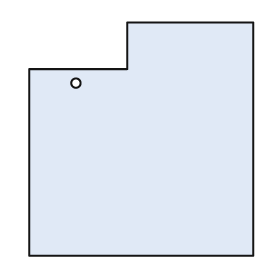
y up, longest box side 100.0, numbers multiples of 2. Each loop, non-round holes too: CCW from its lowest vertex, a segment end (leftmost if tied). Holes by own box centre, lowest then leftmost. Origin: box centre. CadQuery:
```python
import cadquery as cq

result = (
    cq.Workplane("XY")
    .moveTo(-48.0, -50.0)
    .lineTo(48.0, -50.0)
    .lineTo(48.0, 50.0)
    .lineTo(-6.0, 50.0)
    .lineTo(-6.0, 30.0)
    .lineTo(-48.0, 30.0)
    .close()
    .moveTo(-28.0, 24.0)
    .circle(2.0)
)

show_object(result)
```